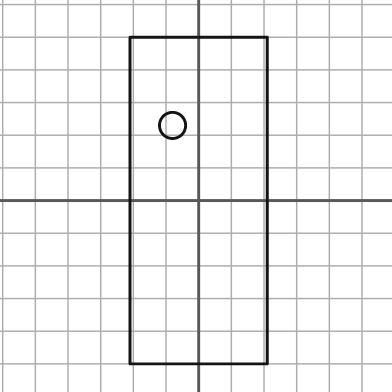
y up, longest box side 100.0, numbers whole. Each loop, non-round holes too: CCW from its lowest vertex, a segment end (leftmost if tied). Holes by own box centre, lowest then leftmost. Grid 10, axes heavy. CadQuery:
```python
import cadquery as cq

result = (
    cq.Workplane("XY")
    .moveTo(-21.0, -50.0)
    .lineTo(21.0, -50.0)
    .lineTo(21.0, 50.0)
    .lineTo(-21.0, 50.0)
    .close()
    .moveTo(-8.0, 23.0)
    .circle(4.0)
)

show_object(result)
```